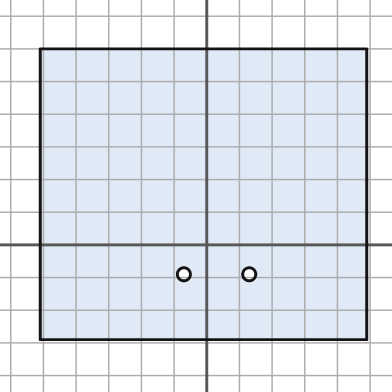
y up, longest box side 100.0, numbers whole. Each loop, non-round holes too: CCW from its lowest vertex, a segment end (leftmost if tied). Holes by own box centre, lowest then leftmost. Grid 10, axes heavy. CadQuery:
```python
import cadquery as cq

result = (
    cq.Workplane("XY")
    .moveTo(-51.0, -29.0)
    .lineTo(49.0, -29.0)
    .lineTo(49.0, 60.0)
    .lineTo(-51.0, 60.0)
    .close()
    .moveTo(-7.0, -9.0)
    .circle(2.0)
    .moveTo(13.0, -9.0)
    .circle(2.0)
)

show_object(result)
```